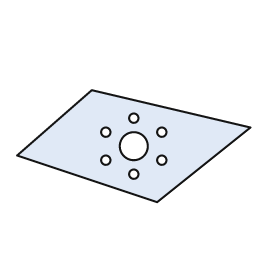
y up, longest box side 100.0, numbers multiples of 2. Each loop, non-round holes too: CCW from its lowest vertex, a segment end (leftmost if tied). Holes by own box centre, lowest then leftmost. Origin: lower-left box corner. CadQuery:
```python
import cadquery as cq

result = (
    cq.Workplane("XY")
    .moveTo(60.0, 0.0)
    .lineTo(100.0, 32.0)
    .lineTo(32.0, 48.0)
    .lineTo(0.0, 20.0)
    .close()
    .moveTo(50.0, 12.0)
    .circle(2.0)
    .moveTo(38.0, 18.0)
    .circle(2.0)
    .moveTo(62.0, 18.0)
    .circle(2.0)
    .moveTo(50.0, 24.0)
    .circle(6.0)
    .moveTo(38.0, 30.0)
    .circle(2.0)
    .moveTo(62.0, 30.0)
    .circle(2.0)
    .moveTo(50.0, 36.0)
    .circle(2.0)
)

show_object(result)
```